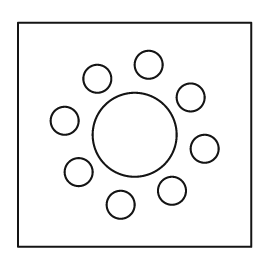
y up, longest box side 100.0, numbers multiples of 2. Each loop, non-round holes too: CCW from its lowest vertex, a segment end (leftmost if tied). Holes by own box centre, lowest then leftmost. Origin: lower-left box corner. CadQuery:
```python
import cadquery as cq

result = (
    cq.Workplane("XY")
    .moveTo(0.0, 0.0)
    .lineTo(100.0, 0.0)
    .lineTo(100.0, 96.0)
    .lineTo(0.0, 96.0)
    .close()
    .moveTo(44.0, 18.0)
    .circle(6.0)
    .moveTo(66.0, 24.0)
    .circle(6.0)
    .moveTo(26.0, 32.0)
    .circle(6.0)
    .moveTo(80.0, 42.0)
    .circle(6.0)
    .moveTo(50.0, 48.0)
    .circle(18.0)
    .moveTo(20.0, 54.0)
    .circle(6.0)
    .moveTo(74.0, 64.0)
    .circle(6.0)
    .moveTo(34.0, 72.0)
    .circle(6.0)
    .moveTo(56.0, 78.0)
    .circle(6.0)
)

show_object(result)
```